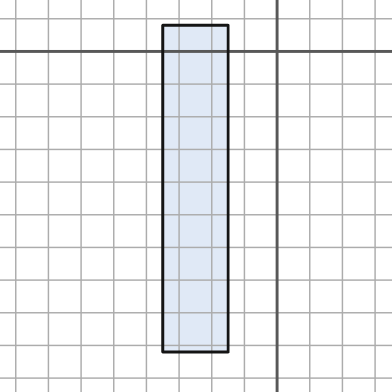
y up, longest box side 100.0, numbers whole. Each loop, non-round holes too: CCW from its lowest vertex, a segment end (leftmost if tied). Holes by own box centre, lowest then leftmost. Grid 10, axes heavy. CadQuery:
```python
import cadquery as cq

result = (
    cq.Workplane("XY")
    .moveTo(-35.0, -92.0)
    .lineTo(-15.0, -92.0)
    .lineTo(-15.0, 8.0)
    .lineTo(-35.0, 8.0)
    .close()
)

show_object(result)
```